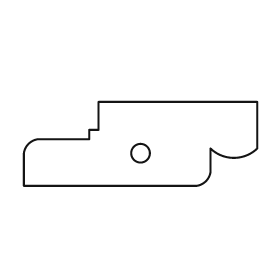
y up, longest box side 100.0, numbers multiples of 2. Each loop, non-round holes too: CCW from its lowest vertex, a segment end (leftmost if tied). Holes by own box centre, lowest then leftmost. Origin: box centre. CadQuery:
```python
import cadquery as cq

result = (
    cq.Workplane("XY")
    .moveTo(-50.0, -18.0)
    .lineTo(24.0, -18.0)
    .threePointArc((28.0, -16.0), (30.0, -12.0))
    .lineTo(30.0, -2.0)
    .threePointArc((40.0, -6.0), (50.0, -2.0))
    .lineTo(50.0, 18.0)
    .lineTo(-18.0, 18.0)
    .lineTo(-18.0, 6.0)
    .lineTo(-22.0, 6.0)
    .lineTo(-22.0, 2.0)
    .lineTo(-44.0, 2.0)
    .threePointArc((-48.0, 0.0), (-50.0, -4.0))
    .close()
    .moveTo(0.0, -4.0)
    .circle(4.0)
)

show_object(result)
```